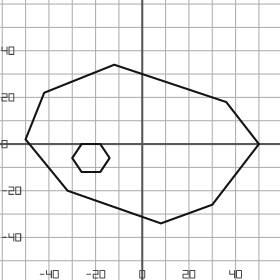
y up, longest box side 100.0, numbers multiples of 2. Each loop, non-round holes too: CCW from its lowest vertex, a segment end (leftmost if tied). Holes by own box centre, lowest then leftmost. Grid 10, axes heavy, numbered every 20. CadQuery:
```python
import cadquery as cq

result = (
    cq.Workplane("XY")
    .moveTo(8.0, -34.0)
    .lineTo(30.0, -26.0)
    .lineTo(50.0, 0.0)
    .lineTo(36.0, 18.0)
    .lineTo(-12.0, 34.0)
    .lineTo(-42.0, 22.0)
    .lineTo(-50.0, 2.0)
    .lineTo(-32.0, -20.0)
    .close()
    .moveTo(-26.0, -12.0)
    .lineTo(-18.0, -12.0)
    .lineTo(-14.0, -6.0)
    .lineTo(-18.0, 0.0)
    .lineTo(-26.0, 0.0)
    .lineTo(-30.0, -6.0)
    .close()
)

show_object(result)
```